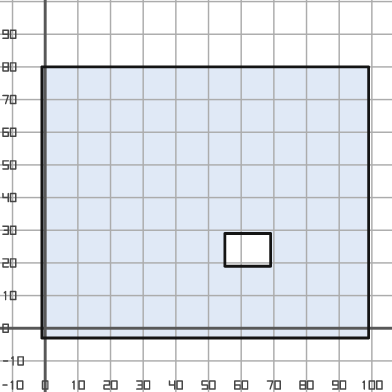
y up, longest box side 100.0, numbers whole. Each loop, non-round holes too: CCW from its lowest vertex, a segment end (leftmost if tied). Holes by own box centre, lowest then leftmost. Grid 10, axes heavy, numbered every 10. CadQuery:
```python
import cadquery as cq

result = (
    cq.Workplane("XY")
    .moveTo(-1.0, -3.0)
    .lineTo(99.0, -3.0)
    .lineTo(99.0, 80.0)
    .lineTo(-1.0, 80.0)
    .close()
    .moveTo(55.0, 19.0)
    .lineTo(69.0, 19.0)
    .lineTo(69.0, 29.0)
    .lineTo(55.0, 29.0)
    .close()
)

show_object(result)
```